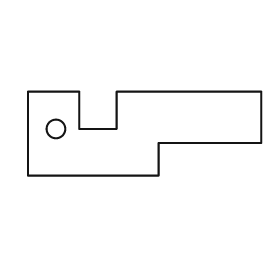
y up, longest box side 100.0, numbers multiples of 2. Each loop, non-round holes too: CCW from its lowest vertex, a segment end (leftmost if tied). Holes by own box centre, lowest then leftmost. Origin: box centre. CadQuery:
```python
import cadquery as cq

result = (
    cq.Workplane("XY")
    .moveTo(-50.0, -18.0)
    .lineTo(6.0, -18.0)
    .lineTo(6.0, -4.0)
    .lineTo(50.0, -4.0)
    .lineTo(50.0, 18.0)
    .lineTo(-12.0, 18.0)
    .lineTo(-12.0, 2.0)
    .lineTo(-28.0, 2.0)
    .lineTo(-28.0, 18.0)
    .lineTo(-50.0, 18.0)
    .close()
    .moveTo(-38.0, 2.0)
    .circle(4.0)
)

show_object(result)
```